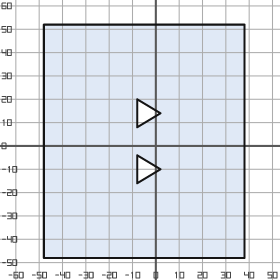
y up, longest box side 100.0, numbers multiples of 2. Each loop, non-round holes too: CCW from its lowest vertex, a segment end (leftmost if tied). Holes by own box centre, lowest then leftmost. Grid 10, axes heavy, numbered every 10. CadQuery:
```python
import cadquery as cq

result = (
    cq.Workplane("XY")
    .moveTo(-48.0, -48.0)
    .lineTo(38.0, -48.0)
    .lineTo(38.0, 52.0)
    .lineTo(-48.0, 52.0)
    .close()
    .moveTo(-8.0, -16.0)
    .lineTo(2.0, -10.0)
    .lineTo(-8.0, -4.0)
    .close()
    .moveTo(-8.0, 8.0)
    .lineTo(2.0, 14.0)
    .lineTo(-8.0, 20.0)
    .close()
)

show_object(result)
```